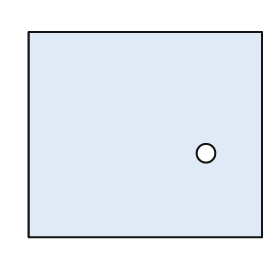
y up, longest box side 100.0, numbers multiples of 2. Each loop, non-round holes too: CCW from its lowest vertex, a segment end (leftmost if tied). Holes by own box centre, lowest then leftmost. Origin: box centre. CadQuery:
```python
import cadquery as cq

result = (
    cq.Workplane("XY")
    .moveTo(-50.0, -44.0)
    .lineTo(50.0, -44.0)
    .lineTo(50.0, 44.0)
    .lineTo(-50.0, 44.0)
    .close()
    .moveTo(26.0, -8.0)
    .circle(4.0)
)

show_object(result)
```